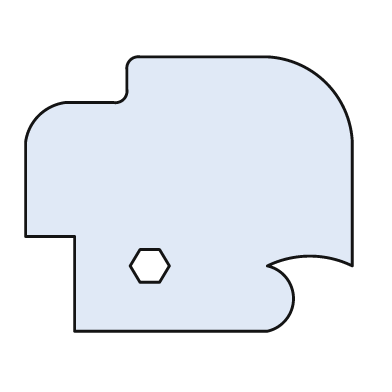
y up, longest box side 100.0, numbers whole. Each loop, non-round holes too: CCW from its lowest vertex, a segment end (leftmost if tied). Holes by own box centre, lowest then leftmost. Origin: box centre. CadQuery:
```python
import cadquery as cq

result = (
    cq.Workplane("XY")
    .moveTo(-35.0, -42.0)
    .lineTo(24.0, -42.0)
    .threePointArc((32.0, -32.0), (24.0, -22.0))
    .threePointArc((37.0, -19.0), (50.0, -22.0))
    .lineTo(50.0, 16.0)
    .threePointArc((42.0, 34.0), (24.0, 42.0))
    .lineTo(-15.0, 42.0)
    .threePointArc((-18.0, 41.0), (-19.0, 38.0))
    .lineTo(-19.0, 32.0)
    .threePointArc((-20.0, 29.0), (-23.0, 28.0))
    .lineTo(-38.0, 28.0)
    .threePointArc((-46.0, 24.0), (-50.0, 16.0))
    .lineTo(-50.0, -13.0)
    .lineTo(-35.0, -13.0)
    .close()
    .moveTo(-15.0, -27.0)
    .lineTo(-9.0, -27.0)
    .lineTo(-6.0, -22.0)
    .lineTo(-9.0, -17.0)
    .lineTo(-15.0, -17.0)
    .lineTo(-18.0, -22.0)
    .close()
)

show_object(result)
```